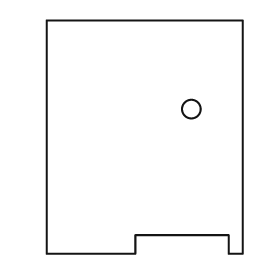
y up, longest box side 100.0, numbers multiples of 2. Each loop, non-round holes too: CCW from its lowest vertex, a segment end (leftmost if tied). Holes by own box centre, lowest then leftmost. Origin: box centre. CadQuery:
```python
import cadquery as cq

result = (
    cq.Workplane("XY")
    .moveTo(-42.0, -50.0)
    .lineTo(-4.0, -50.0)
    .lineTo(-4.0, -42.0)
    .lineTo(36.0, -42.0)
    .lineTo(36.0, -50.0)
    .lineTo(42.0, -50.0)
    .lineTo(42.0, 50.0)
    .lineTo(-42.0, 50.0)
    .close()
    .moveTo(20.0, 12.0)
    .circle(4.0)
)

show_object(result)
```